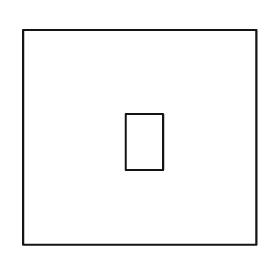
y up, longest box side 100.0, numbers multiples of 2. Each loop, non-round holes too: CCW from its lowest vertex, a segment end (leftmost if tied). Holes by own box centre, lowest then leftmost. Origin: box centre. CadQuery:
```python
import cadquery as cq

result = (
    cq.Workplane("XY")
    .moveTo(-50.0, -46.0)
    .lineTo(50.0, -46.0)
    .lineTo(50.0, 46.0)
    .lineTo(-50.0, 46.0)
    .close()
    .moveTo(-6.0, -14.0)
    .lineTo(10.0, -14.0)
    .lineTo(10.0, 10.0)
    .lineTo(-6.0, 10.0)
    .close()
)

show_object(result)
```